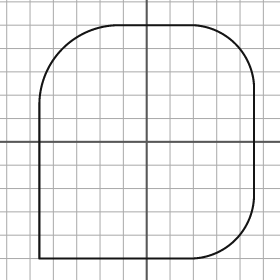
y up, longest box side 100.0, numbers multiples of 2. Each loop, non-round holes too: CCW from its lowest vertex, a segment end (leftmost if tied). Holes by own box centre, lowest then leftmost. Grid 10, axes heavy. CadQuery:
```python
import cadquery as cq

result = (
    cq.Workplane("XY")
    .moveTo(-46.0, -50.0)
    .lineTo(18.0, -50.0)
    .threePointArc((38.0, -42.0), (46.0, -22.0))
    .lineTo(46.0, 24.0)
    .threePointArc((38.0, 42.0), (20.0, 50.0))
    .lineTo(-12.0, 50.0)
    .threePointArc((-36.0, 40.0), (-46.0, 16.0))
    .close()
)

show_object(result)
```